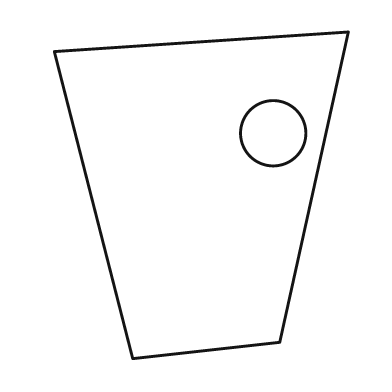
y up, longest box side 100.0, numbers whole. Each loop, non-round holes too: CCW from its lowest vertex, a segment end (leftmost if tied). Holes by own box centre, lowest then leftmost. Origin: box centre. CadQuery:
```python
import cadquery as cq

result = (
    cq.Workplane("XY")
    .moveTo(-21.0, -50.0)
    .lineTo(24.0, -45.0)
    .lineTo(45.0, 50.0)
    .lineTo(-45.0, 44.0)
    .close()
    .moveTo(22.0, 19.0)
    .circle(10.0)
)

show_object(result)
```